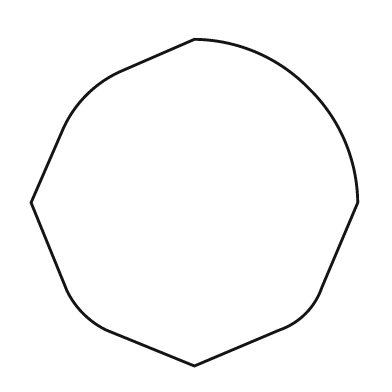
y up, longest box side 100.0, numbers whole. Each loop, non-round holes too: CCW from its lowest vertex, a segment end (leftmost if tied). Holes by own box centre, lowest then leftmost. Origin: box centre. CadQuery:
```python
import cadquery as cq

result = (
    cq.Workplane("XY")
    .moveTo(0.0, -50.0)
    .lineTo(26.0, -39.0)
    .threePointArc((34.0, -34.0), (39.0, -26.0))
    .lineTo(50.0, 0.0)
    .threePointArc((46.0, 19.0), (35.0, 35.0))
    .threePointArc((19.0, 46.0), (0.0, 50.0))
    .lineTo(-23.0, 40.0)
    .threePointArc((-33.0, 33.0), (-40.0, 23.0))
    .lineTo(-50.0, 0.0)
    .lineTo(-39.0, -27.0)
    .threePointArc((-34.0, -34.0), (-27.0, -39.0))
    .close()
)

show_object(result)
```